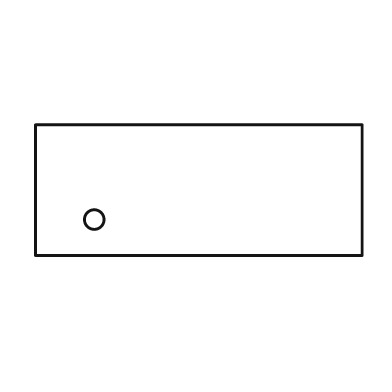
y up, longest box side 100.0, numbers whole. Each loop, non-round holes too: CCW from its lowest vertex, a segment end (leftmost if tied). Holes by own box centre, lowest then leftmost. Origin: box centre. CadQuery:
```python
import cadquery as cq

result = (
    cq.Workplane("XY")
    .moveTo(-50.0, -20.0)
    .lineTo(50.0, -20.0)
    .lineTo(50.0, 20.0)
    .lineTo(-50.0, 20.0)
    .close()
    .moveTo(-32.0, -9.0)
    .circle(3.0)
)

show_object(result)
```